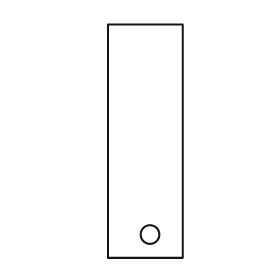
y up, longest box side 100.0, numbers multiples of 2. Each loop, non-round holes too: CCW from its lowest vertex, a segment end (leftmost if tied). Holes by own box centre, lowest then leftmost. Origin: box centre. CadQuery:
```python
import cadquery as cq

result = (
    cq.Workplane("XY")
    .moveTo(-16.0, -50.0)
    .lineTo(16.0, -50.0)
    .lineTo(16.0, 50.0)
    .lineTo(-16.0, 50.0)
    .close()
    .moveTo(2.0, -40.0)
    .circle(4.0)
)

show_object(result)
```